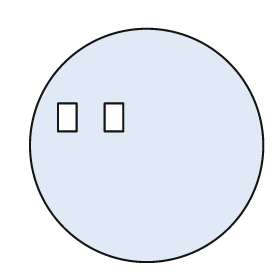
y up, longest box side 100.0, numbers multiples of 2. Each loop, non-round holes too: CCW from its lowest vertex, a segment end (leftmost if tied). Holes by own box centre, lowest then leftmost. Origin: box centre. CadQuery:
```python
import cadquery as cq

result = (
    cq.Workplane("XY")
    .moveTo(0.0, 0.0)
    .circle(50.0)
    .moveTo(-38.0, 6.0)
    .lineTo(-30.0, 6.0)
    .lineTo(-30.0, 18.0)
    .lineTo(-38.0, 18.0)
    .close()
    .moveTo(-18.0, 6.0)
    .lineTo(-10.0, 6.0)
    .lineTo(-10.0, 18.0)
    .lineTo(-18.0, 18.0)
    .close()
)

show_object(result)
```